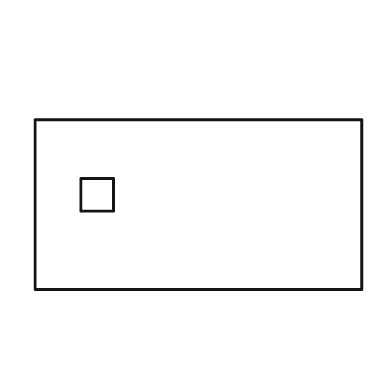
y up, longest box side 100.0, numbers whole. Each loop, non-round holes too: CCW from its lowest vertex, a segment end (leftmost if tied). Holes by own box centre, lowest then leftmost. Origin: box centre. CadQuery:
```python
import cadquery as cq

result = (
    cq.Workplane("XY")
    .moveTo(-50.0, -26.0)
    .lineTo(50.0, -26.0)
    .lineTo(50.0, 26.0)
    .lineTo(-50.0, 26.0)
    .close()
    .moveTo(-36.0, -2.0)
    .lineTo(-26.0, -2.0)
    .lineTo(-26.0, 8.0)
    .lineTo(-36.0, 8.0)
    .close()
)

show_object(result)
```